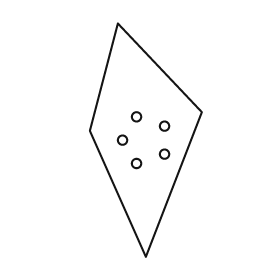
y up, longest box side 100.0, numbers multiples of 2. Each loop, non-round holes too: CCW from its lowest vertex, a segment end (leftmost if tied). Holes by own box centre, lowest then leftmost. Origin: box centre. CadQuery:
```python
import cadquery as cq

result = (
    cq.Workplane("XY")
    .moveTo(0.0, -50.0)
    .lineTo(24.0, 12.0)
    .lineTo(-12.0, 50.0)
    .lineTo(-24.0, 4.0)
    .close()
    .moveTo(-4.0, -10.0)
    .circle(2.0)
    .moveTo(8.0, -6.0)
    .circle(2.0)
    .moveTo(-10.0, 0.0)
    .circle(2.0)
    .moveTo(8.0, 6.0)
    .circle(2.0)
    .moveTo(-4.0, 10.0)
    .circle(2.0)
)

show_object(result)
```